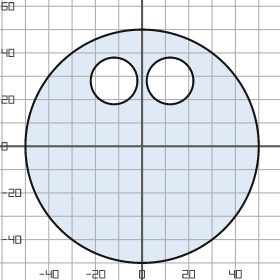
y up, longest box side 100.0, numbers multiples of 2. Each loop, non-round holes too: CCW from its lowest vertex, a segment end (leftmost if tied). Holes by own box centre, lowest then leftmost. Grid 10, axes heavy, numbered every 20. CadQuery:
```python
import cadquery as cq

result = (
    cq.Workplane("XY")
    .moveTo(0.0, 0.0)
    .circle(50.0)
    .moveTo(-12.0, 28.0)
    .circle(10.0)
    .moveTo(12.0, 28.0)
    .circle(10.0)
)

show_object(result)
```